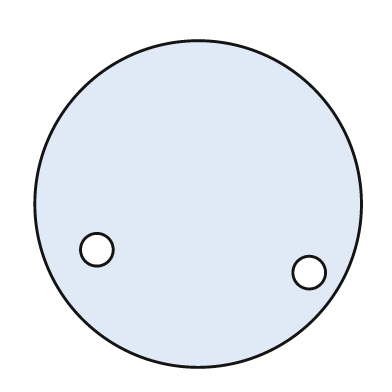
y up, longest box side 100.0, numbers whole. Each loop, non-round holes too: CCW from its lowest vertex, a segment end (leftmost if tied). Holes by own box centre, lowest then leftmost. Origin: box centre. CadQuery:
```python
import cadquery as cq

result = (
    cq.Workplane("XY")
    .moveTo(0.0, 0.0)
    .circle(50.0)
    .moveTo(34.0, -21.0)
    .circle(5.0)
    .moveTo(-31.0, -14.0)
    .circle(5.0)
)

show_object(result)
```